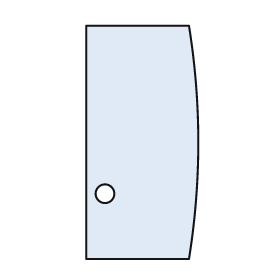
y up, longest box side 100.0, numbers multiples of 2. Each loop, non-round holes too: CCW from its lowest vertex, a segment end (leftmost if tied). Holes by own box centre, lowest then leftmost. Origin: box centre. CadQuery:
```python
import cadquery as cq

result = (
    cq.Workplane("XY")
    .moveTo(-24.0, -50.0)
    .lineTo(20.0, -50.0)
    .threePointArc((24.0, 0.0), (20.0, 50.0))
    .lineTo(-24.0, 50.0)
    .close()
    .moveTo(-16.0, -22.0)
    .circle(4.0)
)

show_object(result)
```